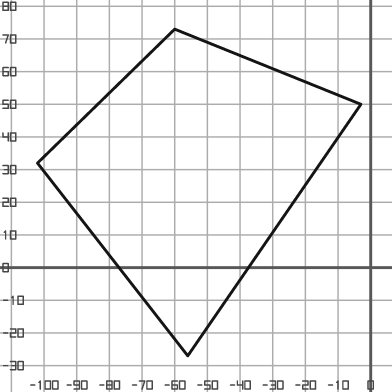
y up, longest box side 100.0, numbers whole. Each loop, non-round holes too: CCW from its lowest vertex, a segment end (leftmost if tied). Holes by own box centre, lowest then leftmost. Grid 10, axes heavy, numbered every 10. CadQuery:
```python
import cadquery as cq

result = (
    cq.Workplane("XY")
    .moveTo(-56.0, -27.0)
    .lineTo(-3.0, 50.0)
    .lineTo(-60.0, 73.0)
    .lineTo(-102.0, 32.0)
    .close()
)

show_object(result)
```